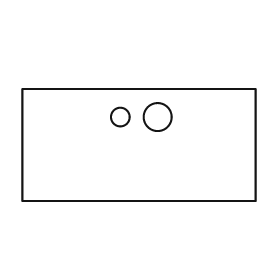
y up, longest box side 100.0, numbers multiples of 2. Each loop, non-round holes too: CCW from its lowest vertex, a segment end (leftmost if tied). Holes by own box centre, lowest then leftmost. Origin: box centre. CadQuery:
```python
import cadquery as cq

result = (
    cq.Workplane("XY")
    .moveTo(-50.0, -24.0)
    .lineTo(50.0, -24.0)
    .lineTo(50.0, 24.0)
    .lineTo(-50.0, 24.0)
    .close()
    .moveTo(-8.0, 12.0)
    .circle(4.0)
    .moveTo(8.0, 12.0)
    .circle(6.0)
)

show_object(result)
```